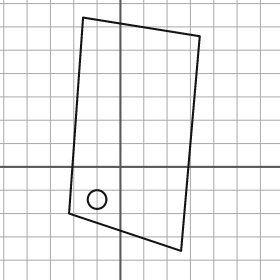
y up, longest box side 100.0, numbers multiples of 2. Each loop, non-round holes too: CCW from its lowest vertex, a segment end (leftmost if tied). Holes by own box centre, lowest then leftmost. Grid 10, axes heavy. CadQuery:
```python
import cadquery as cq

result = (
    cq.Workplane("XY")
    .moveTo(26.0, -36.0)
    .lineTo(34.0, 56.0)
    .lineTo(-16.0, 64.0)
    .lineTo(-22.0, -20.0)
    .close()
    .moveTo(-10.0, -14.0)
    .circle(4.0)
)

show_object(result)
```